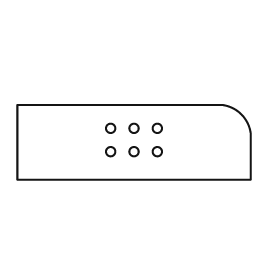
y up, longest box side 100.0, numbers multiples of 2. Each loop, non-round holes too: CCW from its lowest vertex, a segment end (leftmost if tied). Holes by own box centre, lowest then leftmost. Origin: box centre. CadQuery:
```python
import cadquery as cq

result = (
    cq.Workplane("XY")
    .moveTo(-50.0, -16.0)
    .lineTo(50.0, -16.0)
    .lineTo(50.0, 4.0)
    .threePointArc((46.0, 12.0), (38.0, 16.0))
    .lineTo(-50.0, 16.0)
    .close()
    .moveTo(-10.0, -4.0)
    .circle(2.0)
    .moveTo(0.0, -4.0)
    .circle(2.0)
    .moveTo(10.0, -4.0)
    .circle(2.0)
    .moveTo(-10.0, 6.0)
    .circle(2.0)
    .moveTo(0.0, 6.0)
    .circle(2.0)
    .moveTo(10.0, 6.0)
    .circle(2.0)
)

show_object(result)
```